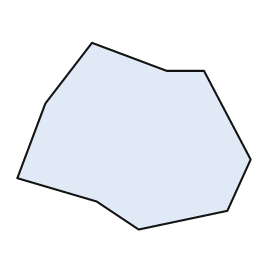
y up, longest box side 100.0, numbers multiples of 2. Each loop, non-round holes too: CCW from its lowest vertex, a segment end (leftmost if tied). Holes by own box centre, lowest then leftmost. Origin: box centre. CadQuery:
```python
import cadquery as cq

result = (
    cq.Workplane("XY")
    .moveTo(2.0, -40.0)
    .lineTo(40.0, -32.0)
    .lineTo(50.0, -10.0)
    .lineTo(30.0, 28.0)
    .lineTo(14.0, 28.0)
    .lineTo(-18.0, 40.0)
    .lineTo(-38.0, 14.0)
    .lineTo(-50.0, -18.0)
    .lineTo(-16.0, -28.0)
    .close()
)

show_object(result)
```